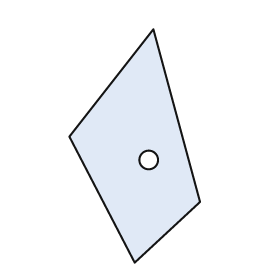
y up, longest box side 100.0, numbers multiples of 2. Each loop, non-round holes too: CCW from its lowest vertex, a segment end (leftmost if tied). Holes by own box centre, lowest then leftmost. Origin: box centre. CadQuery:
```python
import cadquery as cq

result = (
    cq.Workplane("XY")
    .moveTo(0.0, -50.0)
    .lineTo(28.0, -24.0)
    .lineTo(8.0, 50.0)
    .lineTo(-28.0, 4.0)
    .close()
    .moveTo(6.0, -6.0)
    .circle(4.0)
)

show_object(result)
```